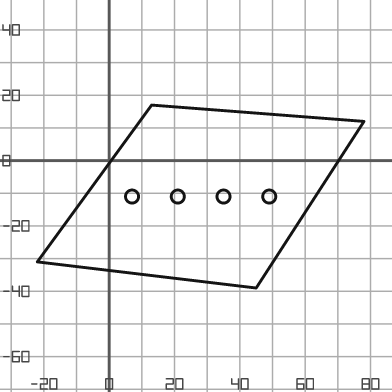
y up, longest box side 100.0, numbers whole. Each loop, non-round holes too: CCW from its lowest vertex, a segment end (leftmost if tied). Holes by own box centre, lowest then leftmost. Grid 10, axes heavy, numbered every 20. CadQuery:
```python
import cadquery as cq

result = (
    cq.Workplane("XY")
    .moveTo(45.0, -39.0)
    .lineTo(78.0, 12.0)
    .lineTo(13.0, 17.0)
    .lineTo(-22.0, -31.0)
    .close()
    .moveTo(7.0, -11.0)
    .circle(2.0)
    .moveTo(21.0, -11.0)
    .circle(2.0)
    .moveTo(35.0, -11.0)
    .circle(2.0)
    .moveTo(49.0, -11.0)
    .circle(2.0)
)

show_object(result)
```